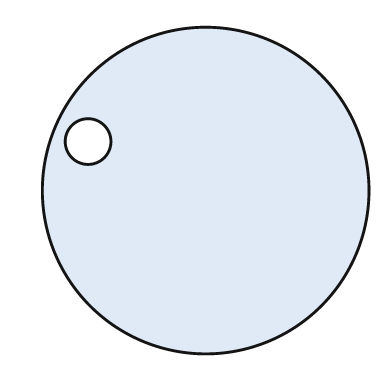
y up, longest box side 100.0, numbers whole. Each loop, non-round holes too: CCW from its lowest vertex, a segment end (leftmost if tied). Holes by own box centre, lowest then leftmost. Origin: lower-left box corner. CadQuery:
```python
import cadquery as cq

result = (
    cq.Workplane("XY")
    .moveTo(50.0, 50.0)
    .circle(50.0)
    .moveTo(14.0, 65.0)
    .circle(7.0)
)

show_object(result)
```